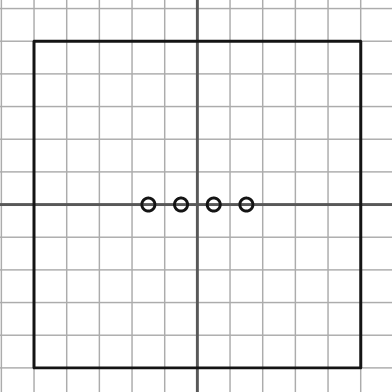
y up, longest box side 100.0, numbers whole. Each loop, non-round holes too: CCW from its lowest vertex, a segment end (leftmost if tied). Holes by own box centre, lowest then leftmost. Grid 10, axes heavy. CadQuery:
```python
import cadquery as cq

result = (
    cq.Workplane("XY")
    .moveTo(-50.0, -50.0)
    .lineTo(50.0, -50.0)
    .lineTo(50.0, 50.0)
    .lineTo(-50.0, 50.0)
    .close()
    .moveTo(-15.0, 0.0)
    .circle(2.0)
    .moveTo(-5.0, 0.0)
    .circle(2.0)
    .moveTo(5.0, 0.0)
    .circle(2.0)
    .moveTo(15.0, 0.0)
    .circle(2.0)
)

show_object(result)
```